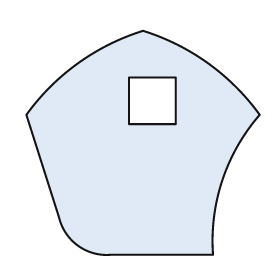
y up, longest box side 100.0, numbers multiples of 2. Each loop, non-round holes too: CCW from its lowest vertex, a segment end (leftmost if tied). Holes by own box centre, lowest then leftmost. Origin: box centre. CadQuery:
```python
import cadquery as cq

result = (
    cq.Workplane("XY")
    .moveTo(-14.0, -48.0)
    .lineTo(30.0, -48.0)
    .threePointArc((34.0, -16.0), (50.0, 12.0))
    .threePointArc((28.0, 34.0), (0.0, 48.0))
    .threePointArc((-28.0, 34.0), (-50.0, 12.0))
    .lineTo(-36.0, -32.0)
    .threePointArc((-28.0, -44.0), (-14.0, -48.0))
    .close()
    .moveTo(-6.0, 8.0)
    .lineTo(14.0, 8.0)
    .lineTo(14.0, 28.0)
    .lineTo(-6.0, 28.0)
    .close()
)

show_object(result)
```